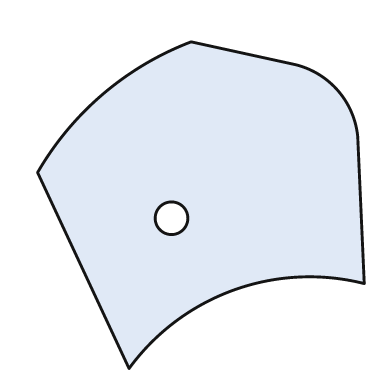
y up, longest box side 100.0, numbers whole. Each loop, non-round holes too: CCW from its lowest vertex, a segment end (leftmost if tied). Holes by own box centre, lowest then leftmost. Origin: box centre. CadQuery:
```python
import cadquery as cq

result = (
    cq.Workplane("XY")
    .moveTo(-22.0, -50.0)
    .threePointArc((10.0, -26.0), (50.0, -24.0))
    .lineTo(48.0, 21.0)
    .threePointArc((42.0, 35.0), (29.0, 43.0))
    .lineTo(-3.0, 50.0)
    .threePointArc((-30.0, 34.0), (-50.0, 10.0))
    .close()
    .moveTo(-9.0, -4.0)
    .circle(5.0)
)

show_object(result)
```